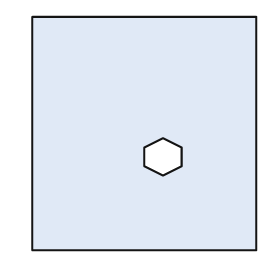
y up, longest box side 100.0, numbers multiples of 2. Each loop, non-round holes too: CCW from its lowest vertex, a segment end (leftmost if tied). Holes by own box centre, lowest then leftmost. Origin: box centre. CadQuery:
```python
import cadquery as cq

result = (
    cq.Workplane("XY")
    .moveTo(-48.0, -50.0)
    .lineTo(48.0, -50.0)
    .lineTo(48.0, 50.0)
    .lineTo(-48.0, 50.0)
    .close()
    .moveTo(8.0, -18.0)
    .lineTo(16.0, -14.0)
    .lineTo(16.0, -6.0)
    .lineTo(8.0, -2.0)
    .lineTo(0.0, -6.0)
    .lineTo(0.0, -14.0)
    .close()
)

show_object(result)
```